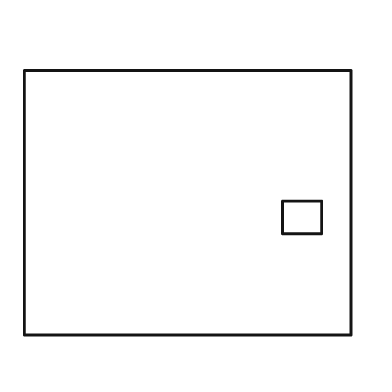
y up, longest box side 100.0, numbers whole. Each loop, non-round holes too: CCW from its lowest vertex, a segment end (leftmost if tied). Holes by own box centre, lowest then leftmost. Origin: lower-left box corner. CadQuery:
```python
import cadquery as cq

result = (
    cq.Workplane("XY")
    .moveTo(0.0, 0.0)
    .lineTo(100.0, 0.0)
    .lineTo(100.0, 81.0)
    .lineTo(0.0, 81.0)
    .close()
    .moveTo(79.0, 31.0)
    .lineTo(91.0, 31.0)
    .lineTo(91.0, 41.0)
    .lineTo(79.0, 41.0)
    .close()
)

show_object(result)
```